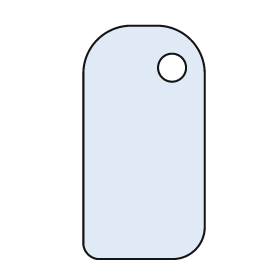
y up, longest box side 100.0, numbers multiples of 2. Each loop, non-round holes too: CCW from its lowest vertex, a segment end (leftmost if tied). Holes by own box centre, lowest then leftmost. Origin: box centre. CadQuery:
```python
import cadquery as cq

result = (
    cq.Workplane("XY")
    .moveTo(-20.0, -50.0)
    .lineTo(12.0, -50.0)
    .threePointArc((22.0, -46.0), (26.0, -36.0))
    .lineTo(26.0, 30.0)
    .threePointArc((20.0, 44.0), (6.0, 50.0))
    .lineTo(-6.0, 50.0)
    .threePointArc((-20.0, 44.0), (-26.0, 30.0))
    .lineTo(-26.0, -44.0)
    .threePointArc((-24.0, -48.0), (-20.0, -50.0))
    .close()
    .moveTo(12.0, 32.0)
    .circle(6.0)
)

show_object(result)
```